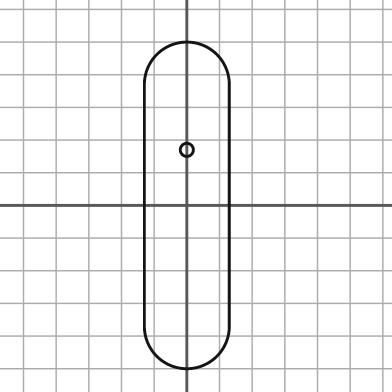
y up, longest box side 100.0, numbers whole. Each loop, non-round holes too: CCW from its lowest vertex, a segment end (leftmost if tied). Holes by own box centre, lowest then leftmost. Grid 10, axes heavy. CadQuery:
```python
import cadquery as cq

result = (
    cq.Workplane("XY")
    .moveTo(-13.0, -37.0)
    .threePointArc((0.0, -50.0), (13.0, -37.0))
    .lineTo(13.0, 37.0)
    .threePointArc((0.0, 50.0), (-13.0, 37.0))
    .close()
    .moveTo(0.0, 17.0)
    .circle(2.0)
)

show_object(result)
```